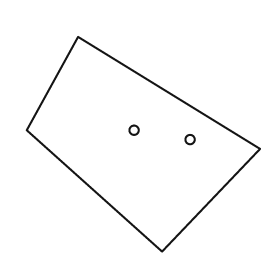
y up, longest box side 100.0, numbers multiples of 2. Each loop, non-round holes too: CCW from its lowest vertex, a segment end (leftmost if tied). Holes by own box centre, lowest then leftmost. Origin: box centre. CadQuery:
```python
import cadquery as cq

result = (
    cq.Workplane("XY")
    .moveTo(8.0, -46.0)
    .lineTo(50.0, -2.0)
    .lineTo(-28.0, 46.0)
    .lineTo(-50.0, 6.0)
    .close()
    .moveTo(20.0, 2.0)
    .circle(2.0)
    .moveTo(-4.0, 6.0)
    .circle(2.0)
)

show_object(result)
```